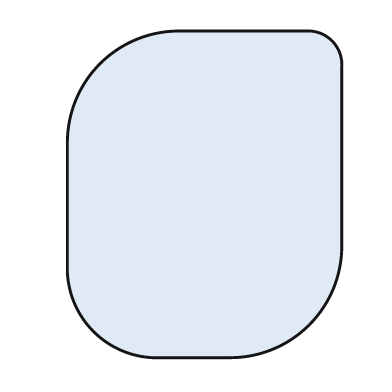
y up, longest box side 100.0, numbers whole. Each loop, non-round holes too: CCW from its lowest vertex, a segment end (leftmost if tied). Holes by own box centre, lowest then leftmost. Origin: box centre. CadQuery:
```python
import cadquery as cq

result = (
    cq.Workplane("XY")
    .moveTo(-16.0, -50.0)
    .lineTo(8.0, -50.0)
    .threePointArc((32.0, -40.0), (42.0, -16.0))
    .lineTo(42.0, 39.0)
    .threePointArc((39.0, 47.0), (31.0, 50.0))
    .lineTo(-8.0, 50.0)
    .threePointArc((-32.0, 40.0), (-42.0, 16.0))
    .lineTo(-42.0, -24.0)
    .threePointArc((-34.0, -42.0), (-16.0, -50.0))
    .close()
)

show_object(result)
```